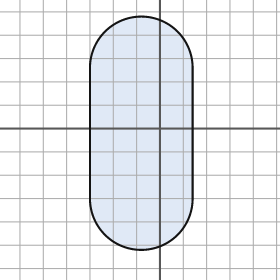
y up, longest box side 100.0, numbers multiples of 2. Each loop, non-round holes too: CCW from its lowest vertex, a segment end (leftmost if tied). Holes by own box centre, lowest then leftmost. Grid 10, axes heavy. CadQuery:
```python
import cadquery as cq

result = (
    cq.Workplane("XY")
    .moveTo(-30.0, -30.0)
    .threePointArc((-8.0, -52.0), (14.0, -30.0))
    .lineTo(14.0, 26.0)
    .threePointArc((-8.0, 48.0), (-30.0, 26.0))
    .close()
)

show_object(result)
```